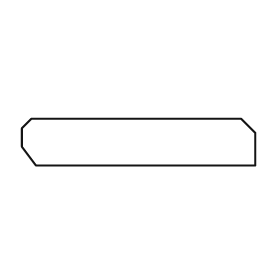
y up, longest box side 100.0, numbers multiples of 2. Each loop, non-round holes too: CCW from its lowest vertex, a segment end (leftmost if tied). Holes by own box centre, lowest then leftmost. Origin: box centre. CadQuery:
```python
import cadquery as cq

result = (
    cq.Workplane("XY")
    .moveTo(-44.0, -10.0)
    .lineTo(50.0, -10.0)
    .lineTo(50.0, 4.0)
    .lineTo(44.0, 10.0)
    .lineTo(-46.0, 10.0)
    .lineTo(-50.0, 6.0)
    .lineTo(-50.0, -2.0)
    .close()
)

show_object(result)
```